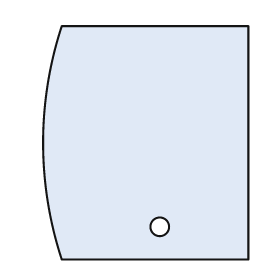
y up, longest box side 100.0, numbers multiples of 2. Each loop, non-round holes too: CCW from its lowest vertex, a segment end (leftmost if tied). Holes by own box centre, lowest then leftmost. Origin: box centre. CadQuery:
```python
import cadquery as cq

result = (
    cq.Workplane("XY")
    .moveTo(-36.0, -50.0)
    .lineTo(44.0, -50.0)
    .lineTo(44.0, 50.0)
    .lineTo(-36.0, 50.0)
    .threePointArc((-44.0, 0.0), (-36.0, -50.0))
    .close()
    .moveTo(6.0, -36.0)
    .circle(4.0)
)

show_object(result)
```